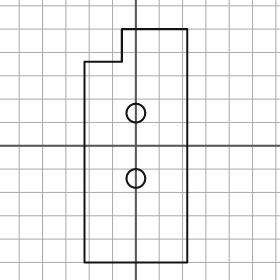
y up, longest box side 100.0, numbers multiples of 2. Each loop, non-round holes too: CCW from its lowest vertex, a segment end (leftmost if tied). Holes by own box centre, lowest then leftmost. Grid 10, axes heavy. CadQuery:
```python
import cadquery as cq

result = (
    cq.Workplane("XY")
    .moveTo(-22.0, -50.0)
    .lineTo(22.0, -50.0)
    .lineTo(22.0, 50.0)
    .lineTo(-6.0, 50.0)
    .lineTo(-6.0, 36.0)
    .lineTo(-22.0, 36.0)
    .close()
    .moveTo(0.0, -14.0)
    .circle(4.0)
    .moveTo(0.0, 14.0)
    .circle(4.0)
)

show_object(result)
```